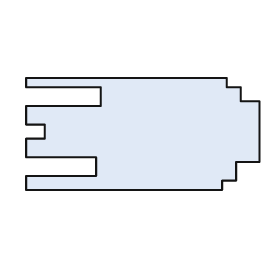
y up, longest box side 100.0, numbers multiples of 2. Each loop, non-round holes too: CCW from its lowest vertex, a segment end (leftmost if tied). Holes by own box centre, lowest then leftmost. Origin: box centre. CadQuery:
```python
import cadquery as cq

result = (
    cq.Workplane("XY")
    .moveTo(-50.0, -24.0)
    .lineTo(34.0, -24.0)
    .lineTo(34.0, -20.0)
    .lineTo(40.0, -20.0)
    .lineTo(40.0, -12.0)
    .lineTo(50.0, -12.0)
    .lineTo(50.0, 14.0)
    .lineTo(42.0, 14.0)
    .lineTo(42.0, 20.0)
    .lineTo(36.0, 20.0)
    .lineTo(36.0, 24.0)
    .lineTo(-50.0, 24.0)
    .lineTo(-50.0, 20.0)
    .lineTo(-18.0, 20.0)
    .lineTo(-18.0, 12.0)
    .lineTo(-50.0, 12.0)
    .lineTo(-50.0, 4.0)
    .lineTo(-42.0, 4.0)
    .lineTo(-42.0, -2.0)
    .lineTo(-50.0, -2.0)
    .lineTo(-50.0, -10.0)
    .lineTo(-20.0, -10.0)
    .lineTo(-20.0, -18.0)
    .lineTo(-50.0, -18.0)
    .close()
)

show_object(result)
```